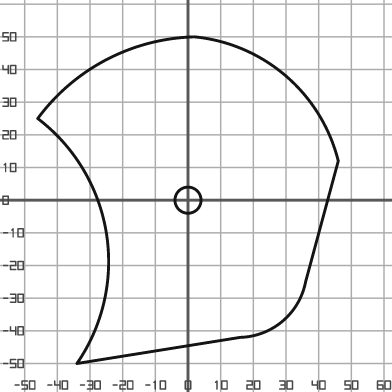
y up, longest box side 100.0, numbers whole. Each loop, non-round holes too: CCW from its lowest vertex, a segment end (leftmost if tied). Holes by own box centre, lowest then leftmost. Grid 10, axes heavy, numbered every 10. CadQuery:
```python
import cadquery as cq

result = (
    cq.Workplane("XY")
    .moveTo(-34.0, -50.0)
    .lineTo(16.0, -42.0)
    .threePointArc((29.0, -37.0), (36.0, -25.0))
    .lineTo(46.0, 12.0)
    .threePointArc((30.0, 38.0), (2.0, 50.0))
    .threePointArc((-25.0, 43.0), (-46.0, 25.0))
    .threePointArc((-25.0, -10.0), (-34.0, -50.0))
    .close()
    .moveTo(0.0, 0.0)
    .circle(4.0)
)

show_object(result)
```